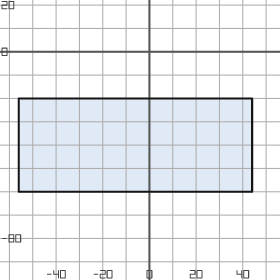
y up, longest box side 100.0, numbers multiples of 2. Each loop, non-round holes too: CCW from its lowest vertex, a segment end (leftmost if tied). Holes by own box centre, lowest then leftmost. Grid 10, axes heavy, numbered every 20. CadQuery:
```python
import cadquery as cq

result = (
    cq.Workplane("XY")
    .moveTo(-56.0, -60.0)
    .lineTo(44.0, -60.0)
    .lineTo(44.0, -20.0)
    .lineTo(-56.0, -20.0)
    .close()
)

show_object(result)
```